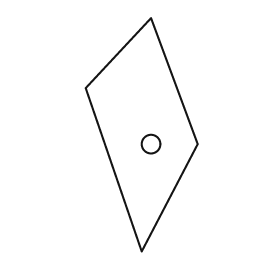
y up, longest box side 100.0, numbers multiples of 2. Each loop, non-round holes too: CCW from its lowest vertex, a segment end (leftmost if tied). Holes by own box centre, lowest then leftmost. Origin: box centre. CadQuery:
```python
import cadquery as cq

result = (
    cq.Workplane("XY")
    .moveTo(0.0, -50.0)
    .lineTo(24.0, -4.0)
    .lineTo(4.0, 50.0)
    .lineTo(-24.0, 20.0)
    .close()
    .moveTo(4.0, -4.0)
    .circle(4.0)
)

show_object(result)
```